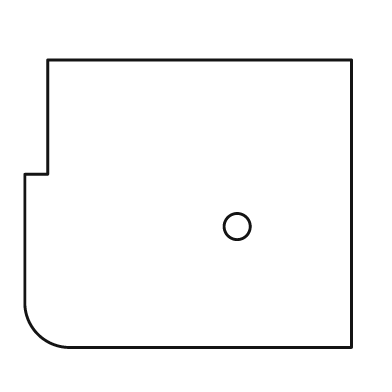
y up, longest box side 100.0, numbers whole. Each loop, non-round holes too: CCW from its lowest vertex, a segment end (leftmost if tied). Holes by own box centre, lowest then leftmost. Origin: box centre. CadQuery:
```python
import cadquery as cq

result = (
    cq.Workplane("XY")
    .moveTo(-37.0, -44.0)
    .lineTo(50.0, -44.0)
    .lineTo(50.0, 44.0)
    .lineTo(-43.0, 44.0)
    .lineTo(-43.0, 9.0)
    .lineTo(-50.0, 9.0)
    .lineTo(-50.0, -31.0)
    .threePointArc((-46.0, -40.0), (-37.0, -44.0))
    .close()
    .moveTo(15.0, -7.0)
    .circle(4.0)
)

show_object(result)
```